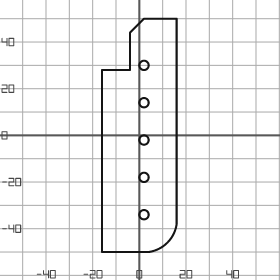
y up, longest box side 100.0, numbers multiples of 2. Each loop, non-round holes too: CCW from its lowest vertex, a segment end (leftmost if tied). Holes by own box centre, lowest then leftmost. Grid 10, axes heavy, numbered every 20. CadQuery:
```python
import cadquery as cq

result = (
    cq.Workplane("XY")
    .moveTo(-16.0, -50.0)
    .lineTo(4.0, -50.0)
    .threePointArc((12.0, -46.0), (16.0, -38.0))
    .lineTo(16.0, 50.0)
    .lineTo(2.0, 50.0)
    .lineTo(-4.0, 44.0)
    .lineTo(-4.0, 28.0)
    .lineTo(-16.0, 28.0)
    .close()
    .moveTo(2.0, -34.0)
    .circle(2.0)
    .moveTo(2.0, -18.0)
    .circle(2.0)
    .moveTo(2.0, -2.0)
    .circle(2.0)
    .moveTo(2.0, 14.0)
    .circle(2.0)
    .moveTo(2.0, 30.0)
    .circle(2.0)
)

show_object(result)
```